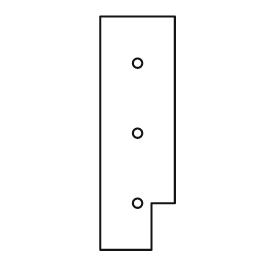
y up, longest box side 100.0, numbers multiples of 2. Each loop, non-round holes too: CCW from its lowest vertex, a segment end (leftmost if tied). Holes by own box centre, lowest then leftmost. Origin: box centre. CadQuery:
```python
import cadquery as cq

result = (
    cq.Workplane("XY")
    .moveTo(-16.0, -50.0)
    .lineTo(6.0, -50.0)
    .lineTo(6.0, -30.0)
    .lineTo(16.0, -30.0)
    .lineTo(16.0, 50.0)
    .lineTo(-16.0, 50.0)
    .close()
    .moveTo(0.0, -30.0)
    .circle(2.0)
    .moveTo(0.0, 0.0)
    .circle(2.0)
    .moveTo(0.0, 30.0)
    .circle(2.0)
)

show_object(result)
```